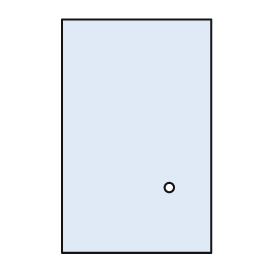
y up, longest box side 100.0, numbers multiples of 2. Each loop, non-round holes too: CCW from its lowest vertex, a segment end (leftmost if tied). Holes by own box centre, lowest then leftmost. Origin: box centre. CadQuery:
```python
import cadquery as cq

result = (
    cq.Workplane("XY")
    .moveTo(-32.0, -50.0)
    .lineTo(32.0, -50.0)
    .lineTo(32.0, 50.0)
    .lineTo(-32.0, 50.0)
    .close()
    .moveTo(14.0, -22.0)
    .circle(2.0)
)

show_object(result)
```